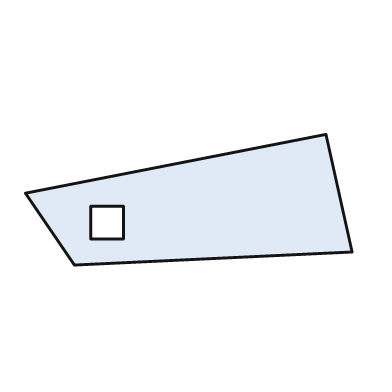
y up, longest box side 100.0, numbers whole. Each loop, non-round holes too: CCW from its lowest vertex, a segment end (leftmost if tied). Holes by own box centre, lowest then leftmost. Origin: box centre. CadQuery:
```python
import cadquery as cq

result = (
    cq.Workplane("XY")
    .moveTo(-35.0, -20.0)
    .lineTo(50.0, -16.0)
    .lineTo(42.0, 20.0)
    .lineTo(-50.0, 2.0)
    .close()
    .moveTo(-30.0, -12.0)
    .lineTo(-20.0, -12.0)
    .lineTo(-20.0, -2.0)
    .lineTo(-30.0, -2.0)
    .close()
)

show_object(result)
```